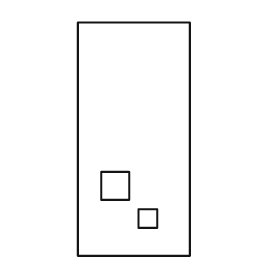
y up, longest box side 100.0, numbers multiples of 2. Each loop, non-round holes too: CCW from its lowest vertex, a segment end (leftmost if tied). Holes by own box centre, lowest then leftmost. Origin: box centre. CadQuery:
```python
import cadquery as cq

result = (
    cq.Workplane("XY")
    .moveTo(-24.0, -50.0)
    .lineTo(24.0, -50.0)
    .lineTo(24.0, 50.0)
    .lineTo(-24.0, 50.0)
    .close()
    .moveTo(2.0, -38.0)
    .lineTo(10.0, -38.0)
    .lineTo(10.0, -30.0)
    .lineTo(2.0, -30.0)
    .close()
    .moveTo(-14.0, -26.0)
    .lineTo(-2.0, -26.0)
    .lineTo(-2.0, -14.0)
    .lineTo(-14.0, -14.0)
    .close()
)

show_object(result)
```